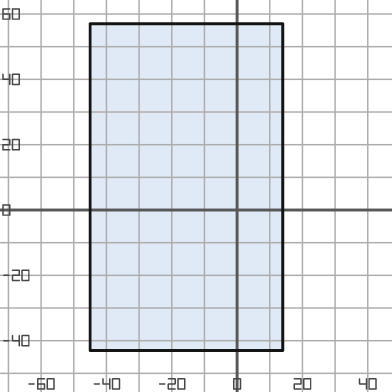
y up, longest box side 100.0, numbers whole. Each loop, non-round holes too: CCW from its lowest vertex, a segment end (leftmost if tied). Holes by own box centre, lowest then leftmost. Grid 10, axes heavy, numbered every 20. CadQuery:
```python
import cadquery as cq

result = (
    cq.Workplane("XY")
    .moveTo(-45.0, -43.0)
    .lineTo(14.0, -43.0)
    .lineTo(14.0, 57.0)
    .lineTo(-45.0, 57.0)
    .close()
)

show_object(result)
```